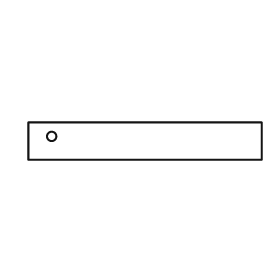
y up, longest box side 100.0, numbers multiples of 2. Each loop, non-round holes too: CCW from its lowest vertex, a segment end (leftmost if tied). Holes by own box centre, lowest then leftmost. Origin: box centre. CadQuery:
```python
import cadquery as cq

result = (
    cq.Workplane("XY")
    .moveTo(-50.0, -8.0)
    .lineTo(50.0, -8.0)
    .lineTo(50.0, 8.0)
    .lineTo(-50.0, 8.0)
    .close()
    .moveTo(-40.0, 2.0)
    .circle(2.0)
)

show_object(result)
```